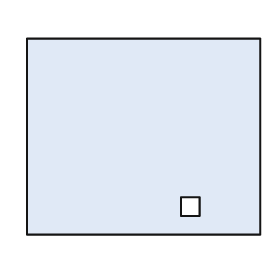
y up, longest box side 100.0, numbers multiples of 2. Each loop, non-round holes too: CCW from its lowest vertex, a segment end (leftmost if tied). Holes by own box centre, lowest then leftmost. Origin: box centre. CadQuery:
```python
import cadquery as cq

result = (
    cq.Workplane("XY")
    .moveTo(-50.0, -42.0)
    .lineTo(50.0, -42.0)
    .lineTo(50.0, 42.0)
    .lineTo(-50.0, 42.0)
    .close()
    .moveTo(16.0, -34.0)
    .lineTo(24.0, -34.0)
    .lineTo(24.0, -26.0)
    .lineTo(16.0, -26.0)
    .close()
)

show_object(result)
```